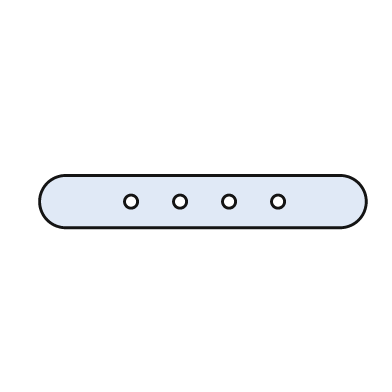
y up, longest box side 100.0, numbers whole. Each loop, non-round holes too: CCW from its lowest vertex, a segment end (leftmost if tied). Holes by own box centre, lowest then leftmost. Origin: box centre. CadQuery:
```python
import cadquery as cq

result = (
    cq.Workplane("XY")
    .moveTo(-42.0, -8.0)
    .lineTo(42.0, -8.0)
    .threePointArc((50.0, 0.0), (42.0, 8.0))
    .lineTo(-42.0, 8.0)
    .threePointArc((-50.0, 0.0), (-42.0, -8.0))
    .close()
    .moveTo(-22.0, 0.0)
    .circle(2.0)
    .moveTo(-7.0, 0.0)
    .circle(2.0)
    .moveTo(8.0, 0.0)
    .circle(2.0)
    .moveTo(23.0, 0.0)
    .circle(2.0)
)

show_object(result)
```